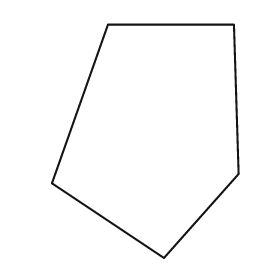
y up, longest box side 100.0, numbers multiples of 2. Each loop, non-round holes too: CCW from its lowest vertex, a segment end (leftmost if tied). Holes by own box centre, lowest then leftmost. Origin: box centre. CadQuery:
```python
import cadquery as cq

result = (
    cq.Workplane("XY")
    .moveTo(8.0, -50.0)
    .lineTo(40.0, -14.0)
    .lineTo(38.0, 50.0)
    .lineTo(-16.0, 50.0)
    .lineTo(-40.0, -18.0)
    .close()
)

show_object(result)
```